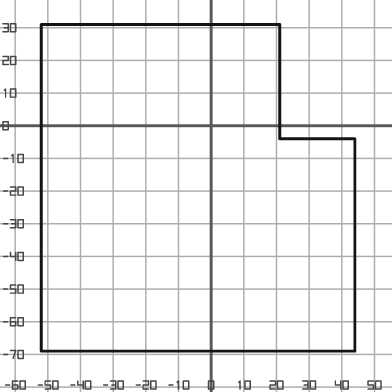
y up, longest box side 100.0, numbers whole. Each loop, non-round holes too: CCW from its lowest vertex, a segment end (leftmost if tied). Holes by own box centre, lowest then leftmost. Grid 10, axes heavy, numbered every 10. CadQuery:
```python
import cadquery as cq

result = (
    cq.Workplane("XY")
    .moveTo(-52.0, -69.0)
    .lineTo(44.0, -69.0)
    .lineTo(44.0, -4.0)
    .lineTo(21.0, -4.0)
    .lineTo(21.0, 31.0)
    .lineTo(-52.0, 31.0)
    .close()
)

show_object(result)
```